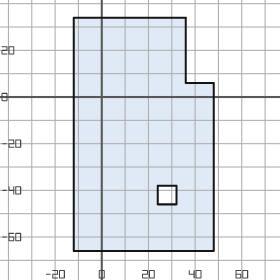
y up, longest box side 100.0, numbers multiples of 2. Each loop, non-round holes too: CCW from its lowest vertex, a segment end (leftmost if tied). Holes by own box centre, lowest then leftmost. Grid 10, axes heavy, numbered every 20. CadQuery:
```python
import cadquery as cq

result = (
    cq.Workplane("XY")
    .moveTo(-12.0, -66.0)
    .lineTo(48.0, -66.0)
    .lineTo(48.0, 6.0)
    .lineTo(36.0, 6.0)
    .lineTo(36.0, 34.0)
    .lineTo(-12.0, 34.0)
    .close()
    .moveTo(24.0, -46.0)
    .lineTo(32.0, -46.0)
    .lineTo(32.0, -38.0)
    .lineTo(24.0, -38.0)
    .close()
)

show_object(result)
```